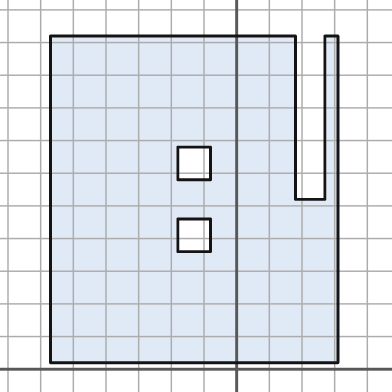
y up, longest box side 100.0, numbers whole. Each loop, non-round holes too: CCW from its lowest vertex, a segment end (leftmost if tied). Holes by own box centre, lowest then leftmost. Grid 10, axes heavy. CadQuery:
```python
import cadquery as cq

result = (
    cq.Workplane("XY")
    .moveTo(-57.0, 2.0)
    .lineTo(31.0, 2.0)
    .lineTo(31.0, 102.0)
    .lineTo(27.0, 102.0)
    .lineTo(27.0, 52.0)
    .lineTo(18.0, 52.0)
    .lineTo(18.0, 102.0)
    .lineTo(-57.0, 102.0)
    .close()
    .moveTo(-18.0, 36.0)
    .lineTo(-8.0, 36.0)
    .lineTo(-8.0, 46.0)
    .lineTo(-18.0, 46.0)
    .close()
    .moveTo(-18.0, 58.0)
    .lineTo(-8.0, 58.0)
    .lineTo(-8.0, 68.0)
    .lineTo(-18.0, 68.0)
    .close()
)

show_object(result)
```